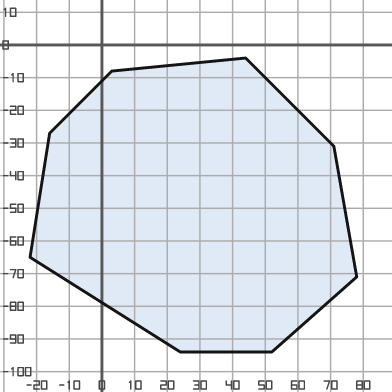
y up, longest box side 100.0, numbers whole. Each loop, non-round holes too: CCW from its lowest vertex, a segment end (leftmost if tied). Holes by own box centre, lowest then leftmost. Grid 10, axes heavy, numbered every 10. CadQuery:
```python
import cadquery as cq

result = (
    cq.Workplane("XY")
    .moveTo(24.0, -94.0)
    .lineTo(52.0, -94.0)
    .lineTo(78.0, -71.0)
    .lineTo(71.0, -31.0)
    .lineTo(44.0, -4.0)
    .lineTo(3.0, -8.0)
    .lineTo(-16.0, -27.0)
    .lineTo(-22.0, -65.0)
    .close()
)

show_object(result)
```